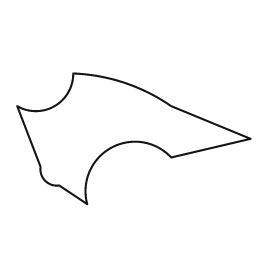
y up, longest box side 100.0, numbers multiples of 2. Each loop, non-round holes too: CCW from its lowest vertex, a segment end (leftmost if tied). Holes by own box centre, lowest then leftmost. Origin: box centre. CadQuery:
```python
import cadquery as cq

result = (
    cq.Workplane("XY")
    .moveTo(-20.0, -28.0)
    .threePointArc((-10.0, -4.0), (16.0, -8.0))
    .lineTo(50.0, 0.0)
    .lineTo(16.0, 14.0)
    .threePointArc((-4.0, 24.0), (-26.0, 28.0))
    .threePointArc((-34.0, 14.0), (-50.0, 14.0))
    .lineTo(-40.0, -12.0)
    .threePointArc((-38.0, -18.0), (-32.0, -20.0))
    .close()
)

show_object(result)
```